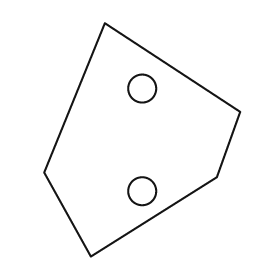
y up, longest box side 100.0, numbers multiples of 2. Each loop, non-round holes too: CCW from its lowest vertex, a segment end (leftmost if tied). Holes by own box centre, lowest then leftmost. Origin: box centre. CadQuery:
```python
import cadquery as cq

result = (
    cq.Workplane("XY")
    .moveTo(-22.0, -50.0)
    .lineTo(32.0, -16.0)
    .lineTo(42.0, 12.0)
    .lineTo(-16.0, 50.0)
    .lineTo(-42.0, -14.0)
    .close()
    .moveTo(0.0, -22.0)
    .circle(6.0)
    .moveTo(0.0, 22.0)
    .circle(6.0)
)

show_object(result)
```